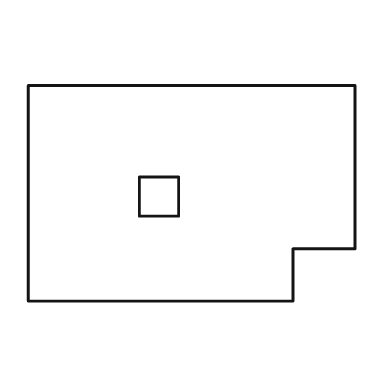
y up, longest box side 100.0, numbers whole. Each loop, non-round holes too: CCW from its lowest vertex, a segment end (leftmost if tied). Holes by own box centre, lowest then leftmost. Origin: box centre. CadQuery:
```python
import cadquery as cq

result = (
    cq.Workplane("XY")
    .moveTo(-50.0, -33.0)
    .lineTo(31.0, -33.0)
    .lineTo(31.0, -17.0)
    .lineTo(50.0, -17.0)
    .lineTo(50.0, 33.0)
    .lineTo(-50.0, 33.0)
    .close()
    .moveTo(-16.0, -7.0)
    .lineTo(-4.0, -7.0)
    .lineTo(-4.0, 5.0)
    .lineTo(-16.0, 5.0)
    .close()
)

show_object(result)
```